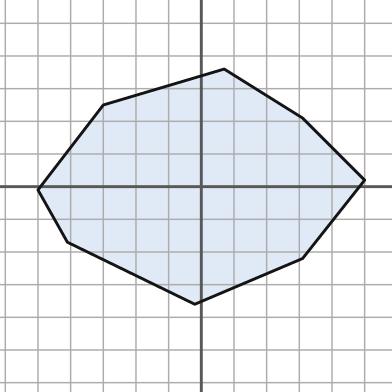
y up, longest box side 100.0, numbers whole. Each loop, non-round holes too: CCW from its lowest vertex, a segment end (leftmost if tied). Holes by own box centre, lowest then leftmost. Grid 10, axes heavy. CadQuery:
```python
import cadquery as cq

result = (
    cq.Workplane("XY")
    .moveTo(-2.0, -36.0)
    .lineTo(31.0, -22.0)
    .lineTo(50.0, 2.0)
    .lineTo(31.0, 21.0)
    .lineTo(7.0, 36.0)
    .lineTo(-30.0, 25.0)
    .lineTo(-50.0, -1.0)
    .lineTo(-41.0, -17.0)
    .close()
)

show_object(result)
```